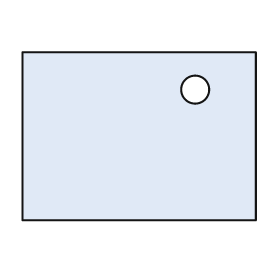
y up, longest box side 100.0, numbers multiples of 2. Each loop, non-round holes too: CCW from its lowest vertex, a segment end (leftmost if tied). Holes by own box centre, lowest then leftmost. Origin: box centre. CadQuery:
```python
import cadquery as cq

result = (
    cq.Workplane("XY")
    .moveTo(-50.0, -36.0)
    .lineTo(50.0, -36.0)
    .lineTo(50.0, 36.0)
    .lineTo(-50.0, 36.0)
    .close()
    .moveTo(24.0, 20.0)
    .circle(6.0)
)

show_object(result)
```